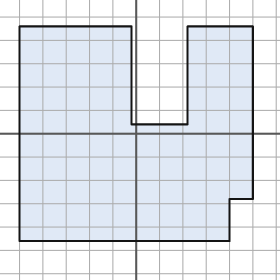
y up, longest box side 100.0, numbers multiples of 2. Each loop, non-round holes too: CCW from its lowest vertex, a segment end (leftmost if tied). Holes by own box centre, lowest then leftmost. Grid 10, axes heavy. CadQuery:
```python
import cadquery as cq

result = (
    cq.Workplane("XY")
    .moveTo(-50.0, -46.0)
    .lineTo(40.0, -46.0)
    .lineTo(40.0, -28.0)
    .lineTo(50.0, -28.0)
    .lineTo(50.0, 46.0)
    .lineTo(22.0, 46.0)
    .lineTo(22.0, 4.0)
    .lineTo(-2.0, 4.0)
    .lineTo(-2.0, 46.0)
    .lineTo(-50.0, 46.0)
    .close()
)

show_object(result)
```